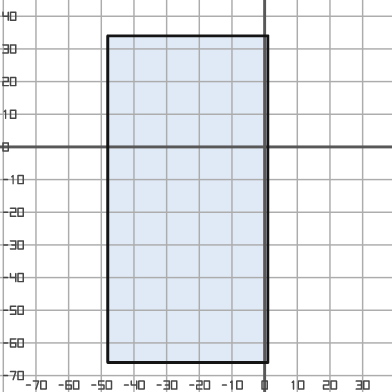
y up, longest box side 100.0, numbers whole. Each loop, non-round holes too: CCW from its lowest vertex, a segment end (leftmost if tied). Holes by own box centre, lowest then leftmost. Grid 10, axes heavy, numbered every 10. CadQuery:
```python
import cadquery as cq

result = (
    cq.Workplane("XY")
    .moveTo(-48.0, -66.0)
    .lineTo(1.0, -66.0)
    .lineTo(1.0, 34.0)
    .lineTo(-48.0, 34.0)
    .close()
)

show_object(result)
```